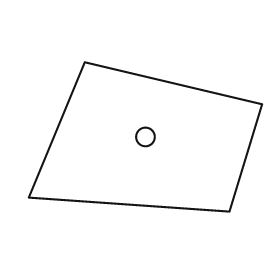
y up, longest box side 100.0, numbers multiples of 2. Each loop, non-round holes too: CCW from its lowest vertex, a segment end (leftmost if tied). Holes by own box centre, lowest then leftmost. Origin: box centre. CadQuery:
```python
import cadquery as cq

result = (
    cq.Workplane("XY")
    .moveTo(36.0, -32.0)
    .lineTo(50.0, 14.0)
    .lineTo(-26.0, 32.0)
    .lineTo(-50.0, -26.0)
    .close()
    .moveTo(0.0, 0.0)
    .circle(4.0)
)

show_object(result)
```